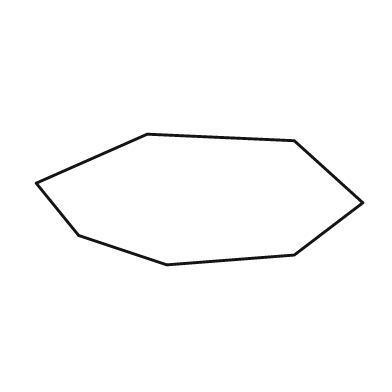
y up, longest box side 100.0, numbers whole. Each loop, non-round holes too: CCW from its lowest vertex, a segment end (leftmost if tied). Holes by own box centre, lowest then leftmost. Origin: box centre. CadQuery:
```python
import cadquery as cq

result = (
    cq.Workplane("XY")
    .moveTo(-10.0, -20.0)
    .lineTo(29.0, -17.0)
    .lineTo(50.0, -1.0)
    .lineTo(29.0, 18.0)
    .lineTo(-16.0, 20.0)
    .lineTo(-50.0, 5.0)
    .lineTo(-37.0, -11.0)
    .close()
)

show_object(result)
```